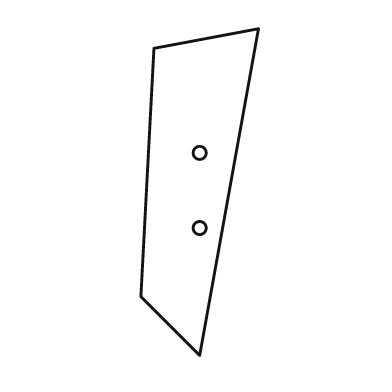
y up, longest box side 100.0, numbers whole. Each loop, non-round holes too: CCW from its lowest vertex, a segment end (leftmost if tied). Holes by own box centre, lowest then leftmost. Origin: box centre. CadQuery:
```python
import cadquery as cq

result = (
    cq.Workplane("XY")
    .moveTo(0.0, -50.0)
    .lineTo(18.0, 50.0)
    .lineTo(-14.0, 44.0)
    .lineTo(-18.0, -32.0)
    .close()
    .moveTo(0.0, -11.0)
    .circle(2.0)
    .moveTo(0.0, 12.0)
    .circle(2.0)
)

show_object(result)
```